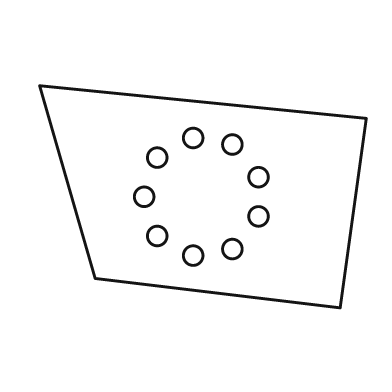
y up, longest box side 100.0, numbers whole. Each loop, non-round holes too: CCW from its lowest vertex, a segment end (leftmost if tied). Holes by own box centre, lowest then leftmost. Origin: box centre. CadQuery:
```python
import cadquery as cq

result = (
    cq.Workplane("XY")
    .moveTo(42.0, -34.0)
    .lineTo(50.0, 24.0)
    .lineTo(-50.0, 34.0)
    .lineTo(-33.0, -25.0)
    .close()
    .moveTo(-3.0, -18.0)
    .circle(3.0)
    .moveTo(9.0, -16.0)
    .circle(3.0)
    .moveTo(-14.0, -12.0)
    .circle(3.0)
    .moveTo(17.0, -6.0)
    .circle(3.0)
    .moveTo(-18.0, 0.0)
    .circle(3.0)
    .moveTo(17.0, 6.0)
    .circle(3.0)
    .moveTo(-14.0, 12.0)
    .circle(3.0)
    .moveTo(9.0, 16.0)
    .circle(3.0)
    .moveTo(-3.0, 18.0)
    .circle(3.0)
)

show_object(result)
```